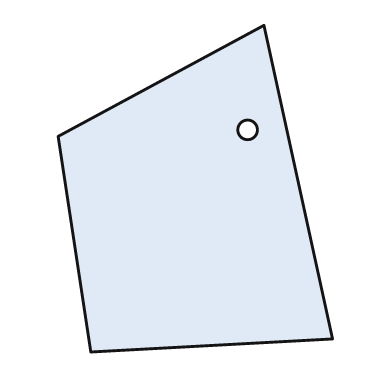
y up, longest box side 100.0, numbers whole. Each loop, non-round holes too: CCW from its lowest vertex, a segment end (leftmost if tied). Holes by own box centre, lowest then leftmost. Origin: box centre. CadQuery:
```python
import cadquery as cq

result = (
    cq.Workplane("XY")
    .moveTo(-32.0, -50.0)
    .lineTo(42.0, -46.0)
    .lineTo(21.0, 50.0)
    .lineTo(-42.0, 16.0)
    .close()
    .moveTo(16.0, 18.0)
    .circle(3.0)
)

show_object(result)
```